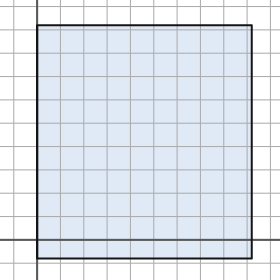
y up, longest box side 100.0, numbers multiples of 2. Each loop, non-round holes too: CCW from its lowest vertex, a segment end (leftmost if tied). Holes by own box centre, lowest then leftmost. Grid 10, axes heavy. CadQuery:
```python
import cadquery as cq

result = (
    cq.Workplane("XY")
    .moveTo(0.0, -8.0)
    .lineTo(92.0, -8.0)
    .lineTo(92.0, 92.0)
    .lineTo(0.0, 92.0)
    .close()
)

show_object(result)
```